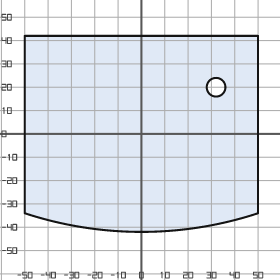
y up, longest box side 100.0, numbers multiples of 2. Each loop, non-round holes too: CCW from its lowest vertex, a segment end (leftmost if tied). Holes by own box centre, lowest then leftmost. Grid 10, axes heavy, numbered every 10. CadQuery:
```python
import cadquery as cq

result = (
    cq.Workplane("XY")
    .moveTo(-50.0, -34.0)
    .threePointArc((0.0, -42.0), (50.0, -34.0))
    .lineTo(50.0, 42.0)
    .lineTo(-50.0, 42.0)
    .close()
    .moveTo(32.0, 20.0)
    .circle(4.0)
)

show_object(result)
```